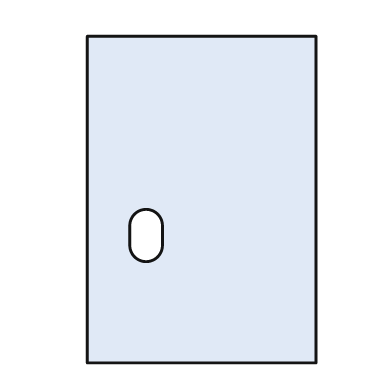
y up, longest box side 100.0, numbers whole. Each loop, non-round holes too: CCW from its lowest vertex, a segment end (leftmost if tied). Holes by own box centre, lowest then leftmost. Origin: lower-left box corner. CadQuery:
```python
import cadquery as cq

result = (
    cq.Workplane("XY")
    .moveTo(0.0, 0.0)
    .lineTo(70.0, 0.0)
    .lineTo(70.0, 100.0)
    .lineTo(0.0, 100.0)
    .close()
    .moveTo(13.0, 36.0)
    .threePointArc((18.0, 31.0), (23.0, 36.0))
    .lineTo(23.0, 42.0)
    .threePointArc((18.0, 47.0), (13.0, 42.0))
    .close()
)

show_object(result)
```